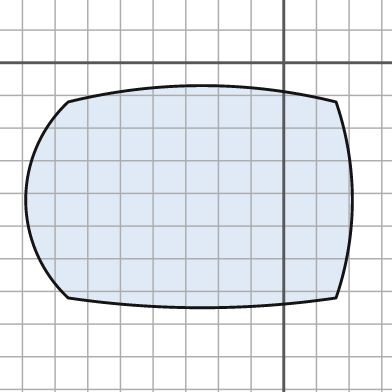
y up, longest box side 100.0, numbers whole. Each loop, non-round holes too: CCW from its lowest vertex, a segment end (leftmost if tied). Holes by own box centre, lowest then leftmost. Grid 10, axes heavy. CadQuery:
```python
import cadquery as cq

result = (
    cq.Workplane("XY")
    .moveTo(-66.0, -72.0)
    .threePointArc((-25.0, -75.0), (16.0, -72.0))
    .threePointArc((21.0, -42.0), (16.0, -12.0))
    .threePointArc((-25.0, -7.0), (-66.0, -12.0))
    .threePointArc((-79.0, -42.0), (-66.0, -72.0))
    .close()
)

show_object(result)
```